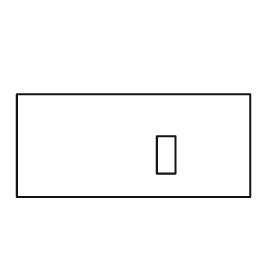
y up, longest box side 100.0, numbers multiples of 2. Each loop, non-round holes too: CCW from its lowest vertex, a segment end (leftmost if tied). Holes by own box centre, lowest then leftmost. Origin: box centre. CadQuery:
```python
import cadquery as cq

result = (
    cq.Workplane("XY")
    .moveTo(-50.0, -22.0)
    .lineTo(50.0, -22.0)
    .lineTo(50.0, 22.0)
    .lineTo(-50.0, 22.0)
    .close()
    .moveTo(10.0, -12.0)
    .lineTo(18.0, -12.0)
    .lineTo(18.0, 4.0)
    .lineTo(10.0, 4.0)
    .close()
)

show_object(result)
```